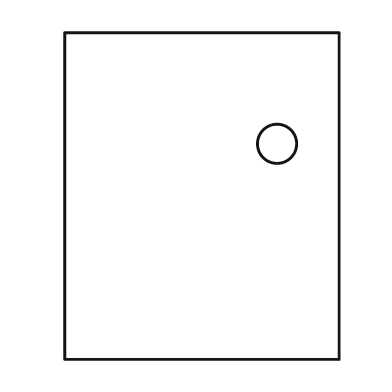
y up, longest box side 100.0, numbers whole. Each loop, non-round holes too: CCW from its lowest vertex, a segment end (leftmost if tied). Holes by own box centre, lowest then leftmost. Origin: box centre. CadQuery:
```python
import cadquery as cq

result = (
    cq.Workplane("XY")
    .moveTo(-42.0, -50.0)
    .lineTo(42.0, -50.0)
    .lineTo(42.0, 50.0)
    .lineTo(-42.0, 50.0)
    .close()
    .moveTo(23.0, 16.0)
    .circle(6.0)
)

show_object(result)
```